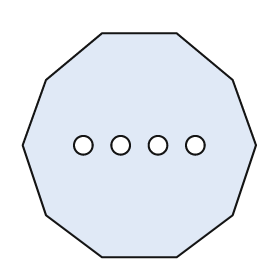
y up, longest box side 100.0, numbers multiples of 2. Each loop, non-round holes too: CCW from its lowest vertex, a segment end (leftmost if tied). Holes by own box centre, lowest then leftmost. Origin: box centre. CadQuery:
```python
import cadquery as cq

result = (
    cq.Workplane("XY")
    .moveTo(-16.0, -48.0)
    .lineTo(16.0, -48.0)
    .lineTo(40.0, -30.0)
    .lineTo(50.0, 0.0)
    .lineTo(40.0, 28.0)
    .lineTo(16.0, 48.0)
    .lineTo(-16.0, 48.0)
    .lineTo(-40.0, 28.0)
    .lineTo(-50.0, 0.0)
    .lineTo(-40.0, -30.0)
    .close()
    .moveTo(-24.0, 0.0)
    .circle(4.0)
    .moveTo(-8.0, 0.0)
    .circle(4.0)
    .moveTo(8.0, 0.0)
    .circle(4.0)
    .moveTo(24.0, 0.0)
    .circle(4.0)
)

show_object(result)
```